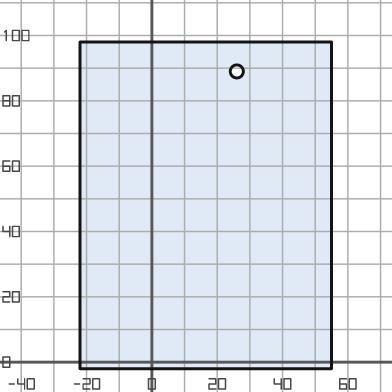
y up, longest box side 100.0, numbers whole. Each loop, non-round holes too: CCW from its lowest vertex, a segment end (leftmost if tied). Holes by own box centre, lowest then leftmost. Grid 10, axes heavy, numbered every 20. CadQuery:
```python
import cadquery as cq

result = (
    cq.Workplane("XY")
    .moveTo(-22.0, -2.0)
    .lineTo(55.0, -2.0)
    .lineTo(55.0, 98.0)
    .lineTo(-22.0, 98.0)
    .close()
    .moveTo(26.0, 89.0)
    .circle(2.0)
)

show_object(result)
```